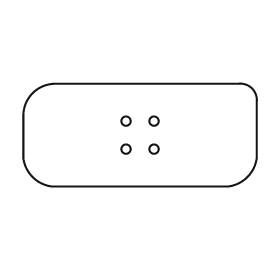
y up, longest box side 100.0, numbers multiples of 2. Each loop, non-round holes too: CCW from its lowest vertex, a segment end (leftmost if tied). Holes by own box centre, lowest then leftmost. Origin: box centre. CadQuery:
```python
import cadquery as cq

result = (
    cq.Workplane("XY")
    .moveTo(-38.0, -22.0)
    .lineTo(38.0, -22.0)
    .threePointArc((46.0, -18.0), (50.0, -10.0))
    .lineTo(50.0, 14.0)
    .threePointArc((48.0, 20.0), (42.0, 22.0))
    .lineTo(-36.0, 22.0)
    .threePointArc((-46.0, 18.0), (-50.0, 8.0))
    .lineTo(-50.0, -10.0)
    .threePointArc((-46.0, -18.0), (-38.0, -22.0))
    .close()
    .moveTo(-6.0, -6.0)
    .circle(2.0)
    .moveTo(6.0, -6.0)
    .circle(2.0)
    .moveTo(-6.0, 6.0)
    .circle(2.0)
    .moveTo(6.0, 6.0)
    .circle(2.0)
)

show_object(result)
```